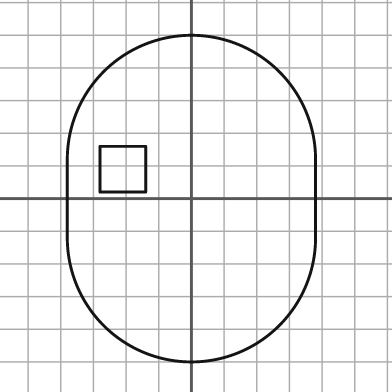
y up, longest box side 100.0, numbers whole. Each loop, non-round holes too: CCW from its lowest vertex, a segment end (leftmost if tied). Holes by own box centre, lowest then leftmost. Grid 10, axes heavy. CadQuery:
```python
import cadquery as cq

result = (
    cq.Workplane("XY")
    .moveTo(-38.0, -12.0)
    .threePointArc((0.0, -50.0), (38.0, -12.0))
    .lineTo(38.0, 12.0)
    .threePointArc((0.0, 50.0), (-38.0, 12.0))
    .close()
    .moveTo(-28.0, 2.0)
    .lineTo(-14.0, 2.0)
    .lineTo(-14.0, 16.0)
    .lineTo(-28.0, 16.0)
    .close()
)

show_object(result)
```